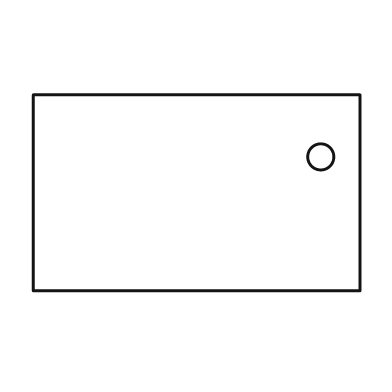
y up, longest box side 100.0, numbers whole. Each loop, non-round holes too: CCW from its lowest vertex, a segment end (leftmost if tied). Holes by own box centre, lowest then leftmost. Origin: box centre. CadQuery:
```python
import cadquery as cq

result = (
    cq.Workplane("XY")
    .moveTo(-50.0, -30.0)
    .lineTo(50.0, -30.0)
    .lineTo(50.0, 30.0)
    .lineTo(-50.0, 30.0)
    .close()
    .moveTo(38.0, 11.0)
    .circle(4.0)
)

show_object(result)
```